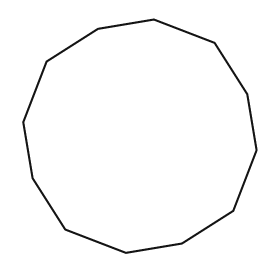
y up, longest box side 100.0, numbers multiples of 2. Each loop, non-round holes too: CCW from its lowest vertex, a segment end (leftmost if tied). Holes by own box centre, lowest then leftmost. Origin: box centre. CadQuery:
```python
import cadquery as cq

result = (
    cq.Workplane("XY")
    .moveTo(-6.0, -50.0)
    .lineTo(18.0, -46.0)
    .lineTo(40.0, -32.0)
    .lineTo(50.0, -6.0)
    .lineTo(46.0, 18.0)
    .lineTo(32.0, 40.0)
    .lineTo(6.0, 50.0)
    .lineTo(-18.0, 46.0)
    .lineTo(-40.0, 32.0)
    .lineTo(-50.0, 6.0)
    .lineTo(-46.0, -18.0)
    .lineTo(-32.0, -40.0)
    .close()
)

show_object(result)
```